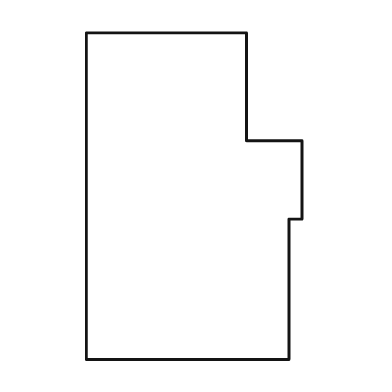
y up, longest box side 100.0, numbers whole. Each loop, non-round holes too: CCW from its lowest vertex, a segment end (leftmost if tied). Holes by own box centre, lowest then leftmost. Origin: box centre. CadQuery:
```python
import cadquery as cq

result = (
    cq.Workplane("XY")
    .moveTo(-33.0, -50.0)
    .lineTo(29.0, -50.0)
    .lineTo(29.0, -7.0)
    .lineTo(33.0, -7.0)
    .lineTo(33.0, 17.0)
    .lineTo(16.0, 17.0)
    .lineTo(16.0, 50.0)
    .lineTo(-33.0, 50.0)
    .close()
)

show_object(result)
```